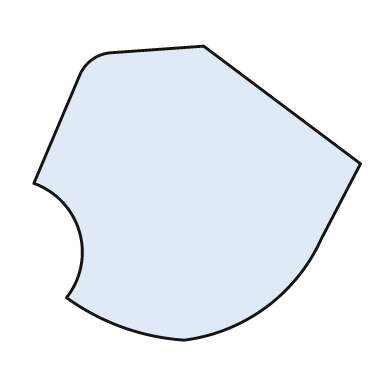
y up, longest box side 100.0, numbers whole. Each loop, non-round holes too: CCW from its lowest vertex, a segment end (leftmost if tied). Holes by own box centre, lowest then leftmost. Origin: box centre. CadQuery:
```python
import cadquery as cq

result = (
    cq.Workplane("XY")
    .moveTo(-4.0, -45.0)
    .threePointArc((21.0, -35.0), (38.0, -14.0))
    .lineTo(50.0, 9.0)
    .lineTo(2.0, 45.0)
    .lineTo(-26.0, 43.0)
    .threePointArc((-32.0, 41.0), (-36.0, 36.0))
    .lineTo(-50.0, 3.0)
    .threePointArc((-36.0, -12.0), (-40.0, -32.0))
    .threePointArc((-23.0, -41.0), (-4.0, -45.0))
    .close()
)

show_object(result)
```